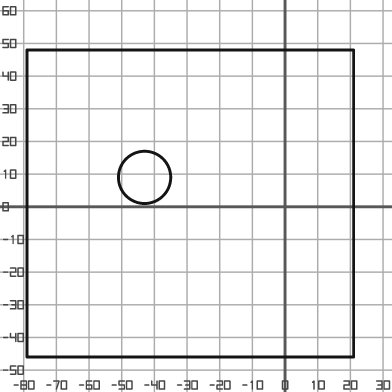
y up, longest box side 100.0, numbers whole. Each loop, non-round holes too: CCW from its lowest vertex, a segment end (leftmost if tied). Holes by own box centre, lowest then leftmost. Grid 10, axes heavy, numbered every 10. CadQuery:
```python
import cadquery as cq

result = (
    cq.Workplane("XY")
    .moveTo(-79.0, -46.0)
    .lineTo(21.0, -46.0)
    .lineTo(21.0, 48.0)
    .lineTo(-79.0, 48.0)
    .close()
    .moveTo(-43.0, 9.0)
    .circle(8.0)
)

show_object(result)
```